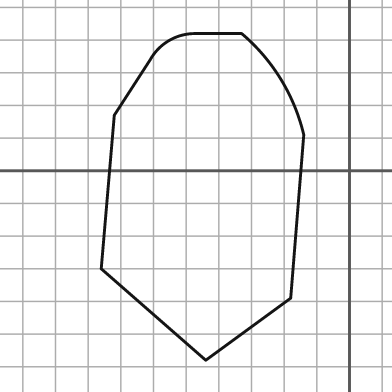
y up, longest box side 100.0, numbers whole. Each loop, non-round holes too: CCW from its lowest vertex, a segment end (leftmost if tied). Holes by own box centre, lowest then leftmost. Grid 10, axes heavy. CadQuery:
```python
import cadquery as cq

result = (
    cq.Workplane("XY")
    .moveTo(-44.0, -58.0)
    .lineTo(-18.0, -39.0)
    .lineTo(-14.0, 11.0)
    .threePointArc((-21.0, 28.0), (-33.0, 42.0))
    .lineTo(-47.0, 42.0)
    .threePointArc((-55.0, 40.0), (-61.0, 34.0))
    .lineTo(-72.0, 17.0)
    .lineTo(-76.0, -30.0)
    .close()
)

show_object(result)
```